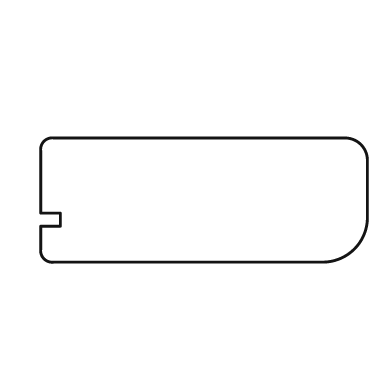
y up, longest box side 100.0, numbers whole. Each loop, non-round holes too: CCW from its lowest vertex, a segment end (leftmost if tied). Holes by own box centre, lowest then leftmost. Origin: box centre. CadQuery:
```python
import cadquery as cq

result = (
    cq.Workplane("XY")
    .moveTo(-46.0, -19.0)
    .lineTo(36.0, -19.0)
    .threePointArc((46.0, -15.0), (50.0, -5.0))
    .lineTo(50.0, 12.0)
    .threePointArc((48.0, 17.0), (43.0, 19.0))
    .lineTo(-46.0, 19.0)
    .threePointArc((-49.0, 18.0), (-50.0, 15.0))
    .lineTo(-50.0, -4.0)
    .lineTo(-44.0, -4.0)
    .lineTo(-44.0, -8.0)
    .lineTo(-50.0, -8.0)
    .lineTo(-50.0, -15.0)
    .threePointArc((-49.0, -18.0), (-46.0, -19.0))
    .close()
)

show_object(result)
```